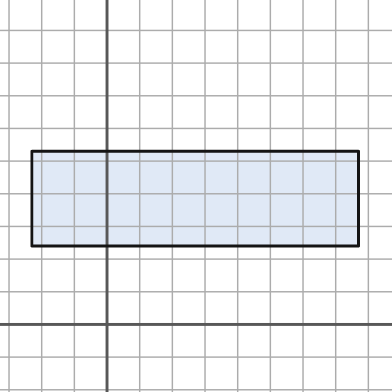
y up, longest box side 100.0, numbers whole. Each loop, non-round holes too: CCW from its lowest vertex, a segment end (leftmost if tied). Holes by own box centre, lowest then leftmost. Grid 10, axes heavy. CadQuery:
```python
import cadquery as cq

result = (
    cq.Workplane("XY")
    .moveTo(-23.0, 24.0)
    .lineTo(77.0, 24.0)
    .lineTo(77.0, 53.0)
    .lineTo(-23.0, 53.0)
    .close()
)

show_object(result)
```